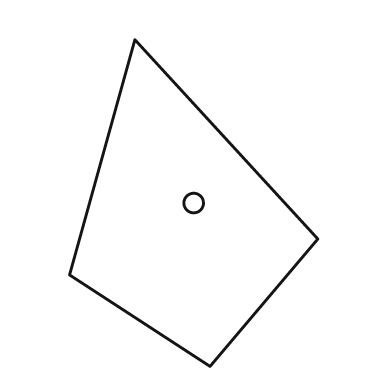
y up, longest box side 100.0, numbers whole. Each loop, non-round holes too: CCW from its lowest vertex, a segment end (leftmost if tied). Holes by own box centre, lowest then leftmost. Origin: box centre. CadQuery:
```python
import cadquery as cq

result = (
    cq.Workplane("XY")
    .moveTo(5.0, -50.0)
    .lineTo(38.0, -11.0)
    .lineTo(-18.0, 50.0)
    .lineTo(-38.0, -22.0)
    .close()
    .moveTo(0.0, 0.0)
    .circle(3.0)
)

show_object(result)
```